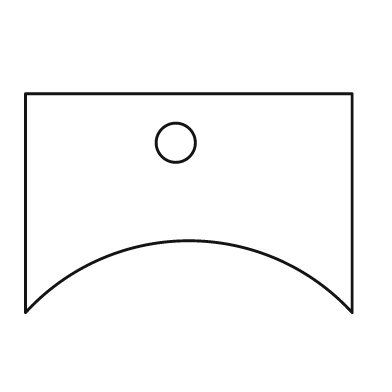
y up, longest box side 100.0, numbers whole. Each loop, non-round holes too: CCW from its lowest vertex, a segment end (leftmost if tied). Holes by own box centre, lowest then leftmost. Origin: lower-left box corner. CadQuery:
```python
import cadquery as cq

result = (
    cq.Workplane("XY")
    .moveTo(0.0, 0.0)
    .threePointArc((50.0, 22.0), (100.0, 0.0))
    .lineTo(100.0, 67.0)
    .lineTo(0.0, 67.0)
    .close()
    .moveTo(46.0, 52.0)
    .circle(6.0)
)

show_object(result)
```